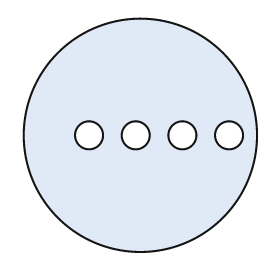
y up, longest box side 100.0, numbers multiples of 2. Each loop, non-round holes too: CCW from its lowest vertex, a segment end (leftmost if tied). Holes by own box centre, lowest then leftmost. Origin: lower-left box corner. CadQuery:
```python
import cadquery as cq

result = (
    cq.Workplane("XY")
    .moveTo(50.0, 50.0)
    .circle(50.0)
    .moveTo(28.0, 50.0)
    .circle(6.0)
    .moveTo(48.0, 50.0)
    .circle(6.0)
    .moveTo(68.0, 50.0)
    .circle(6.0)
    .moveTo(88.0, 50.0)
    .circle(6.0)
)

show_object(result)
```